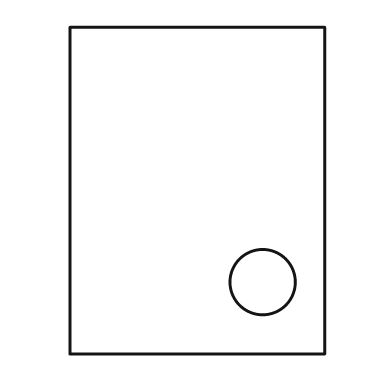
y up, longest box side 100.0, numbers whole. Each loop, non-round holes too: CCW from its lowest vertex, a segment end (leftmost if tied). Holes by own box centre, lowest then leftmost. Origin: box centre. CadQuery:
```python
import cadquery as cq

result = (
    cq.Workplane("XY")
    .moveTo(-39.0, -50.0)
    .lineTo(39.0, -50.0)
    .lineTo(39.0, 50.0)
    .lineTo(-39.0, 50.0)
    .close()
    .moveTo(20.0, -28.0)
    .circle(10.0)
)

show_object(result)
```